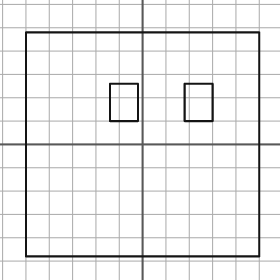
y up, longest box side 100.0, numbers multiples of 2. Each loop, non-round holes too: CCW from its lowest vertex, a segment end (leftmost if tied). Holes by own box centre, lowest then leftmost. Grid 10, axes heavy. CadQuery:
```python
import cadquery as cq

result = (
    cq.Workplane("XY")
    .moveTo(-50.0, -48.0)
    .lineTo(50.0, -48.0)
    .lineTo(50.0, 48.0)
    .lineTo(-50.0, 48.0)
    .close()
    .moveTo(-14.0, 10.0)
    .lineTo(-2.0, 10.0)
    .lineTo(-2.0, 26.0)
    .lineTo(-14.0, 26.0)
    .close()
    .moveTo(18.0, 10.0)
    .lineTo(30.0, 10.0)
    .lineTo(30.0, 26.0)
    .lineTo(18.0, 26.0)
    .close()
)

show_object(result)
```